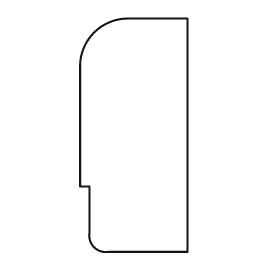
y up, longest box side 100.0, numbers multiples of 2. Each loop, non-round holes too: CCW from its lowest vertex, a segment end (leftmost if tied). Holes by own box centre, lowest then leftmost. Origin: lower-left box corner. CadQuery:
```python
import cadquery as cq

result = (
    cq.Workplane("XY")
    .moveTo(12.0, 0.0)
    .lineTo(46.0, 0.0)
    .lineTo(46.0, 100.0)
    .lineTo(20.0, 100.0)
    .threePointArc((6.0, 94.0), (0.0, 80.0))
    .lineTo(0.0, 28.0)
    .lineTo(4.0, 28.0)
    .lineTo(4.0, 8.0)
    .threePointArc((6.0, 2.0), (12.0, 0.0))
    .close()
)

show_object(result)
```